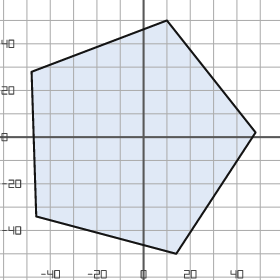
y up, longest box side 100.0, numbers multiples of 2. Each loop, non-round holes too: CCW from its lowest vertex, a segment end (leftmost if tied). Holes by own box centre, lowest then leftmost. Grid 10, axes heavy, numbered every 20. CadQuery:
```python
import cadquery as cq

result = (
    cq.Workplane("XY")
    .moveTo(14.0, -50.0)
    .lineTo(48.0, 2.0)
    .lineTo(10.0, 50.0)
    .lineTo(-48.0, 28.0)
    .lineTo(-46.0, -34.0)
    .close()
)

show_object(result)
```